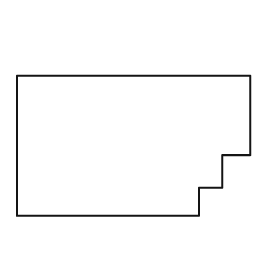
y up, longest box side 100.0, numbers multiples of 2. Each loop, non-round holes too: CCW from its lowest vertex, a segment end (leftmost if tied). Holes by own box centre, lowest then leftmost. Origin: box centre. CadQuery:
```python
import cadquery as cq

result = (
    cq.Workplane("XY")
    .moveTo(-50.0, -30.0)
    .lineTo(28.0, -30.0)
    .lineTo(28.0, -18.0)
    .lineTo(38.0, -18.0)
    .lineTo(38.0, -4.0)
    .lineTo(50.0, -4.0)
    .lineTo(50.0, 30.0)
    .lineTo(-50.0, 30.0)
    .close()
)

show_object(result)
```